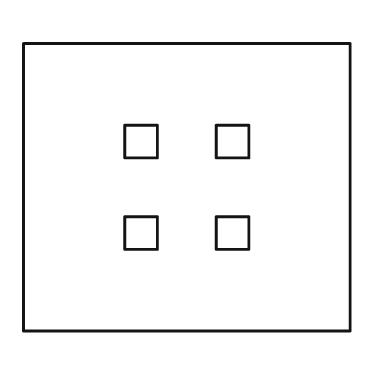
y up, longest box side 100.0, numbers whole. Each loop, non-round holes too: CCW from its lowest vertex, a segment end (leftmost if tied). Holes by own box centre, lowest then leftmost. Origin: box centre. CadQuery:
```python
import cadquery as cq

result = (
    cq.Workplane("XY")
    .moveTo(-50.0, -44.0)
    .lineTo(50.0, -44.0)
    .lineTo(50.0, 44.0)
    .lineTo(-50.0, 44.0)
    .close()
    .moveTo(-19.0, -19.0)
    .lineTo(-9.0, -19.0)
    .lineTo(-9.0, -9.0)
    .lineTo(-19.0, -9.0)
    .close()
    .moveTo(9.0, -19.0)
    .lineTo(19.0, -19.0)
    .lineTo(19.0, -9.0)
    .lineTo(9.0, -9.0)
    .close()
    .moveTo(-19.0, 9.0)
    .lineTo(-9.0, 9.0)
    .lineTo(-9.0, 19.0)
    .lineTo(-19.0, 19.0)
    .close()
    .moveTo(9.0, 9.0)
    .lineTo(19.0, 9.0)
    .lineTo(19.0, 19.0)
    .lineTo(9.0, 19.0)
    .close()
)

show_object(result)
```